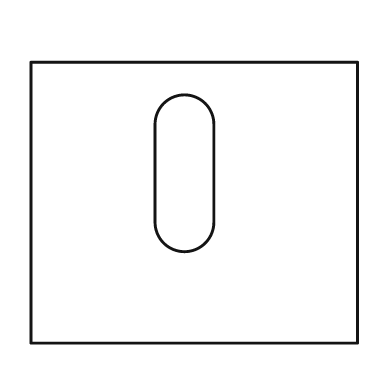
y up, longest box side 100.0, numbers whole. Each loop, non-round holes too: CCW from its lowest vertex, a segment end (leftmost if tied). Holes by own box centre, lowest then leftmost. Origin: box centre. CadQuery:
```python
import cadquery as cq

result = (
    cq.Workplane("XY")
    .moveTo(-50.0, -43.0)
    .lineTo(50.0, -43.0)
    .lineTo(50.0, 43.0)
    .lineTo(-50.0, 43.0)
    .close()
    .moveTo(-12.0, -6.0)
    .threePointArc((-3.0, -15.0), (6.0, -6.0))
    .lineTo(6.0, 24.0)
    .threePointArc((-3.0, 33.0), (-12.0, 24.0))
    .close()
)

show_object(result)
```